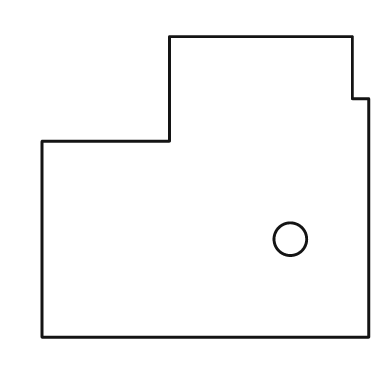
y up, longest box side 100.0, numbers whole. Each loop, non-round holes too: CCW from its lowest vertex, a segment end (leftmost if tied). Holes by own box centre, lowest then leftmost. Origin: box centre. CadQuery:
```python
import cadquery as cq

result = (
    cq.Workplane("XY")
    .moveTo(-50.0, -46.0)
    .lineTo(50.0, -46.0)
    .lineTo(50.0, 27.0)
    .lineTo(45.0, 27.0)
    .lineTo(45.0, 46.0)
    .lineTo(-11.0, 46.0)
    .lineTo(-11.0, 14.0)
    .lineTo(-50.0, 14.0)
    .close()
    .moveTo(26.0, -16.0)
    .circle(5.0)
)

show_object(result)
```